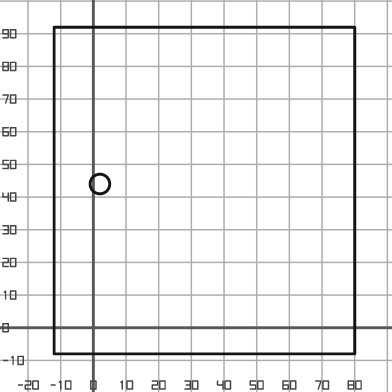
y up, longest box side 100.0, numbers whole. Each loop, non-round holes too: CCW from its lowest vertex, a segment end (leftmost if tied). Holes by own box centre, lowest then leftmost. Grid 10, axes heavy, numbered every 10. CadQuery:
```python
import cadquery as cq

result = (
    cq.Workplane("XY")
    .moveTo(-12.0, -8.0)
    .lineTo(80.0, -8.0)
    .lineTo(80.0, 92.0)
    .lineTo(-12.0, 92.0)
    .close()
    .moveTo(2.0, 44.0)
    .circle(3.0)
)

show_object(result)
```